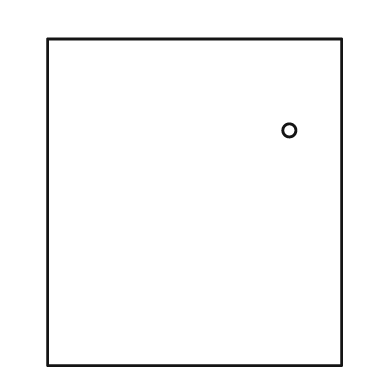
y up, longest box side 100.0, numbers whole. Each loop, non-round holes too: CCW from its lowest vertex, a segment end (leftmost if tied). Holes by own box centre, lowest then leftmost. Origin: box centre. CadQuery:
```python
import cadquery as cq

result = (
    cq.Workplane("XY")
    .moveTo(-45.0, -50.0)
    .lineTo(45.0, -50.0)
    .lineTo(45.0, 50.0)
    .lineTo(-45.0, 50.0)
    .close()
    .moveTo(29.0, 22.0)
    .circle(2.0)
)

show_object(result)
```